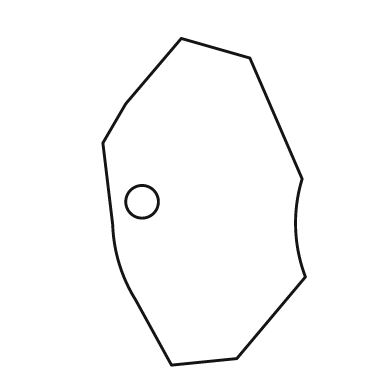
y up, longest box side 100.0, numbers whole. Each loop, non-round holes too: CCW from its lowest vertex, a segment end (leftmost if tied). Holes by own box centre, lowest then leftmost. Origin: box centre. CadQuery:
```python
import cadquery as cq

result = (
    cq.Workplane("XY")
    .moveTo(-10.0, -50.0)
    .lineTo(10.0, -48.0)
    .lineTo(31.0, -23.0)
    .threePointArc((28.0, -8.0), (30.0, 7.0))
    .lineTo(14.0, 44.0)
    .lineTo(-7.0, 50.0)
    .lineTo(-24.0, 30.0)
    .lineTo(-31.0, 18.0)
    .lineTo(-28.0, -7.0)
    .threePointArc((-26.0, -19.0), (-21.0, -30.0))
    .close()
    .moveTo(-19.0, 0.0)
    .circle(5.0)
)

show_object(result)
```